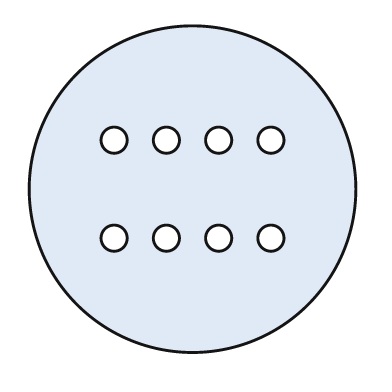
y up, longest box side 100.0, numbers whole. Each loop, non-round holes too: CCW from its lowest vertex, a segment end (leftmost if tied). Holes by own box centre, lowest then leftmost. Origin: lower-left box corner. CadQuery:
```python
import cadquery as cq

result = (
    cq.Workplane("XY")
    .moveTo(50.0, 50.0)
    .circle(50.0)
    .moveTo(26.0, 35.0)
    .circle(4.0)
    .moveTo(42.0, 35.0)
    .circle(4.0)
    .moveTo(58.0, 35.0)
    .circle(4.0)
    .moveTo(74.0, 35.0)
    .circle(4.0)
    .moveTo(26.0, 65.0)
    .circle(4.0)
    .moveTo(42.0, 65.0)
    .circle(4.0)
    .moveTo(58.0, 65.0)
    .circle(4.0)
    .moveTo(74.0, 65.0)
    .circle(4.0)
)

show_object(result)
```